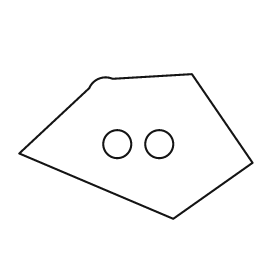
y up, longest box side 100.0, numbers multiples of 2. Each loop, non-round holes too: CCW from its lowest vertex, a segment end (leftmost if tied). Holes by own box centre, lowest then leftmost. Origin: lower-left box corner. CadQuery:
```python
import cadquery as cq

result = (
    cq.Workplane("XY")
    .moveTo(66.0, 0.0)
    .lineTo(100.0, 24.0)
    .lineTo(74.0, 62.0)
    .lineTo(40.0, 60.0)
    .threePointArc((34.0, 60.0), (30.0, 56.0))
    .lineTo(0.0, 28.0)
    .close()
    .moveTo(42.0, 32.0)
    .circle(6.0)
    .moveTo(60.0, 32.0)
    .circle(6.0)
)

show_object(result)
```